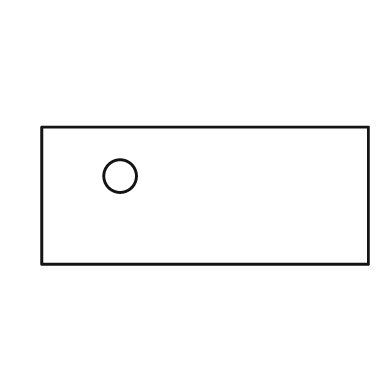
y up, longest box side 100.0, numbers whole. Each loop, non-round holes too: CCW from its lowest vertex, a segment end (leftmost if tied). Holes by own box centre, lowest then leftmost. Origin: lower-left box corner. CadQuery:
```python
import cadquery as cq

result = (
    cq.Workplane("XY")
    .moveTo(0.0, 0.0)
    .lineTo(100.0, 0.0)
    .lineTo(100.0, 42.0)
    .lineTo(0.0, 42.0)
    .close()
    .moveTo(24.0, 27.0)
    .circle(5.0)
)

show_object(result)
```